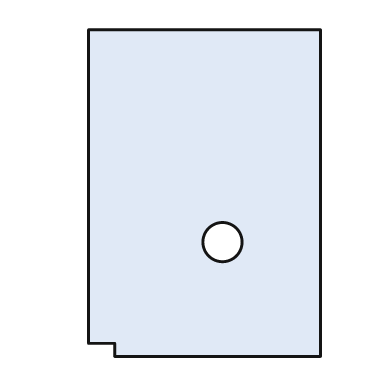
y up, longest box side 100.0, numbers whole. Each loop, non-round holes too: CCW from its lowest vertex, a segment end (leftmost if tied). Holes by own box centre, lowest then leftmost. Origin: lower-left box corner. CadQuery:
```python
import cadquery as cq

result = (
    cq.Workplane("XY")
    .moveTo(8.0, 0.0)
    .lineTo(71.0, 0.0)
    .lineTo(71.0, 100.0)
    .lineTo(0.0, 100.0)
    .lineTo(0.0, 4.0)
    .lineTo(8.0, 4.0)
    .close()
    .moveTo(41.0, 35.0)
    .circle(6.0)
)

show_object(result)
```